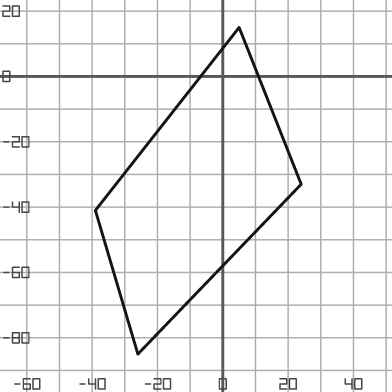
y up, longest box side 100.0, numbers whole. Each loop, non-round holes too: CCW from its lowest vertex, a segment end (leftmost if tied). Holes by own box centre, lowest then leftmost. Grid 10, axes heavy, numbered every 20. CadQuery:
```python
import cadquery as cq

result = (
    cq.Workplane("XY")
    .moveTo(-26.0, -85.0)
    .lineTo(24.0, -33.0)
    .lineTo(5.0, 15.0)
    .lineTo(-39.0, -41.0)
    .close()
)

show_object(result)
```